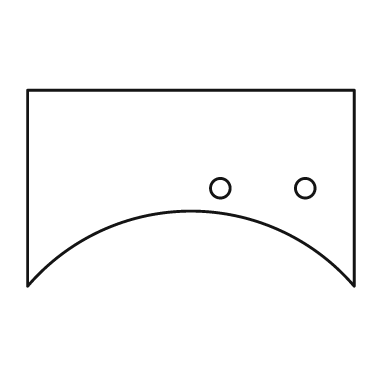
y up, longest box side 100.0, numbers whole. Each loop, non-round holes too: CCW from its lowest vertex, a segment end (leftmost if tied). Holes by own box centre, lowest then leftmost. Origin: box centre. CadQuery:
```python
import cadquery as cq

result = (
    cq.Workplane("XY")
    .moveTo(-50.0, -30.0)
    .threePointArc((0.0, -7.0), (50.0, -30.0))
    .lineTo(50.0, 30.0)
    .lineTo(-50.0, 30.0)
    .close()
    .moveTo(9.0, 0.0)
    .circle(3.0)
    .moveTo(35.0, 0.0)
    .circle(3.0)
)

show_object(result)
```